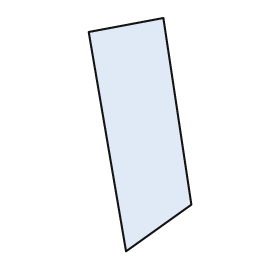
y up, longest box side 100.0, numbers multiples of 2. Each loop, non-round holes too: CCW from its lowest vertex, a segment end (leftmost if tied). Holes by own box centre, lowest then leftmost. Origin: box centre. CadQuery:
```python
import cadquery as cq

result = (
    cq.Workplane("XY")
    .moveTo(-6.0, -50.0)
    .lineTo(22.0, -30.0)
    .lineTo(10.0, 50.0)
    .lineTo(-22.0, 44.0)
    .close()
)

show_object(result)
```